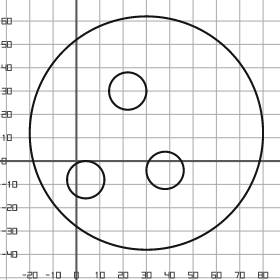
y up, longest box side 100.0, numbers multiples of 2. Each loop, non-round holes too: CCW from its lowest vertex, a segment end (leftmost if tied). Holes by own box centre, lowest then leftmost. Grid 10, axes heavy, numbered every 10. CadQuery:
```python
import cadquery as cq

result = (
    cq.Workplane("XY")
    .moveTo(30.0, 12.0)
    .circle(50.0)
    .moveTo(4.0, -8.0)
    .circle(8.0)
    .moveTo(38.0, -4.0)
    .circle(8.0)
    .moveTo(22.0, 30.0)
    .circle(8.0)
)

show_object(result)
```